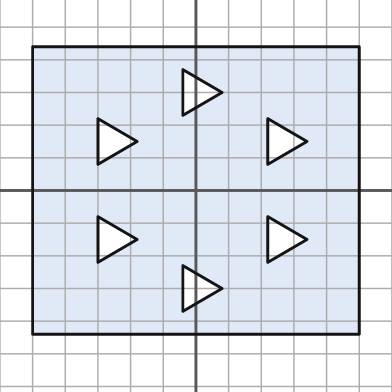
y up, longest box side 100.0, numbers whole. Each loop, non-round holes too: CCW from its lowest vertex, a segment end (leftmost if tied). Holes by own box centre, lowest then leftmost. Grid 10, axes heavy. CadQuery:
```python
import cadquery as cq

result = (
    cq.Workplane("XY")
    .moveTo(-50.0, -44.0)
    .lineTo(50.0, -44.0)
    .lineTo(50.0, 44.0)
    .lineTo(-50.0, 44.0)
    .close()
    .moveTo(-4.0, -37.0)
    .lineTo(8.0, -30.0)
    .lineTo(-4.0, -23.0)
    .close()
    .moveTo(-30.0, -22.0)
    .lineTo(-18.0, -15.0)
    .lineTo(-30.0, -8.0)
    .close()
    .moveTo(22.0, -22.0)
    .lineTo(34.0, -15.0)
    .lineTo(22.0, -8.0)
    .close()
    .moveTo(-30.0, 8.0)
    .lineTo(-18.0, 15.0)
    .lineTo(-30.0, 22.0)
    .close()
    .moveTo(22.0, 8.0)
    .lineTo(34.0, 15.0)
    .lineTo(22.0, 22.0)
    .close()
    .moveTo(-4.0, 23.0)
    .lineTo(8.0, 30.0)
    .lineTo(-4.0, 37.0)
    .close()
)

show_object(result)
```